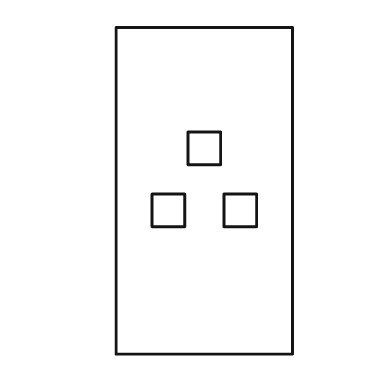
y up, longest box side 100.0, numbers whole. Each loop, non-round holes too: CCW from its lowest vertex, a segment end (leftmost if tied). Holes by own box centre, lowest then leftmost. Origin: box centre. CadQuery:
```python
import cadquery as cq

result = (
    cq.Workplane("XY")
    .moveTo(-27.0, -50.0)
    .lineTo(27.0, -50.0)
    .lineTo(27.0, 50.0)
    .lineTo(-27.0, 50.0)
    .close()
    .moveTo(-16.0, -11.0)
    .lineTo(-6.0, -11.0)
    .lineTo(-6.0, -1.0)
    .lineTo(-16.0, -1.0)
    .close()
    .moveTo(6.0, -11.0)
    .lineTo(16.0, -11.0)
    .lineTo(16.0, -1.0)
    .lineTo(6.0, -1.0)
    .close()
    .moveTo(-5.0, 8.0)
    .lineTo(5.0, 8.0)
    .lineTo(5.0, 18.0)
    .lineTo(-5.0, 18.0)
    .close()
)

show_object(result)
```